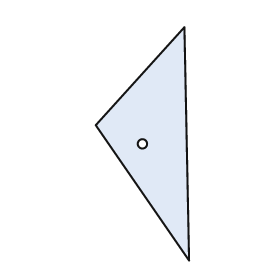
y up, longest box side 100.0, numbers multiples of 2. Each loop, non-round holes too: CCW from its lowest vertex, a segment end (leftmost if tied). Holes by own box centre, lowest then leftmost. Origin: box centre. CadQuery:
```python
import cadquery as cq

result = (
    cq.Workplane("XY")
    .moveTo(20.0, -50.0)
    .lineTo(18.0, 50.0)
    .lineTo(-20.0, 8.0)
    .close()
    .moveTo(0.0, 0.0)
    .circle(2.0)
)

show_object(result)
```